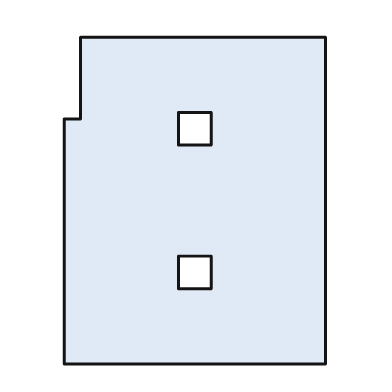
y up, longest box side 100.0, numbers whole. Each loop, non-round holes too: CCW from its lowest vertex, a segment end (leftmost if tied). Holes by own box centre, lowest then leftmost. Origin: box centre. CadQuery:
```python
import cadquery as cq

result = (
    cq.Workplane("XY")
    .moveTo(-40.0, -50.0)
    .lineTo(40.0, -50.0)
    .lineTo(40.0, 50.0)
    .lineTo(-35.0, 50.0)
    .lineTo(-35.0, 25.0)
    .lineTo(-40.0, 25.0)
    .close()
    .moveTo(-5.0, -27.0)
    .lineTo(5.0, -27.0)
    .lineTo(5.0, -17.0)
    .lineTo(-5.0, -17.0)
    .close()
    .moveTo(-5.0, 17.0)
    .lineTo(5.0, 17.0)
    .lineTo(5.0, 27.0)
    .lineTo(-5.0, 27.0)
    .close()
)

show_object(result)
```